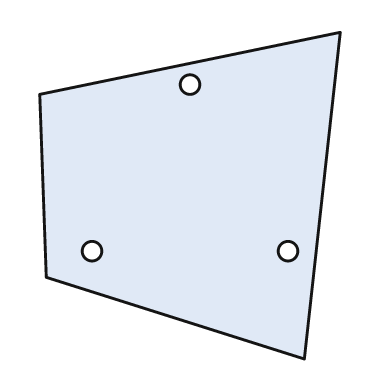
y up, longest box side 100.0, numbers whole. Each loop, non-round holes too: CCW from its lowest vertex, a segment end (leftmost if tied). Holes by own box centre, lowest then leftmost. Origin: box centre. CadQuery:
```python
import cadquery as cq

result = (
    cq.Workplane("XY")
    .moveTo(35.0, -50.0)
    .lineTo(46.0, 50.0)
    .lineTo(-46.0, 31.0)
    .lineTo(-44.0, -25.0)
    .close()
    .moveTo(-30.0, -17.0)
    .circle(3.0)
    .moveTo(30.0, -17.0)
    .circle(3.0)
    .moveTo(0.0, 34.0)
    .circle(3.0)
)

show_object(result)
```